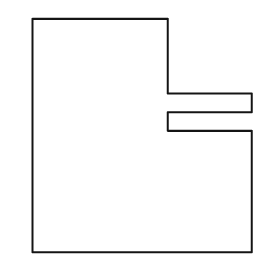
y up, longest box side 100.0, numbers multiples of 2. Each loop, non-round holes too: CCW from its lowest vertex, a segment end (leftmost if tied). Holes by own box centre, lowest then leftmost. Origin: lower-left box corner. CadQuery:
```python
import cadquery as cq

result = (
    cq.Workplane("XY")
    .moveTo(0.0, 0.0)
    .lineTo(94.0, 0.0)
    .lineTo(94.0, 52.0)
    .lineTo(58.0, 52.0)
    .lineTo(58.0, 60.0)
    .lineTo(94.0, 60.0)
    .lineTo(94.0, 68.0)
    .lineTo(58.0, 68.0)
    .lineTo(58.0, 100.0)
    .lineTo(0.0, 100.0)
    .close()
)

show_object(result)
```